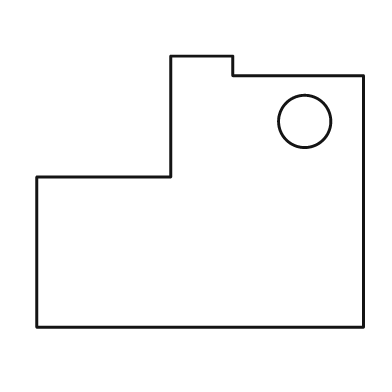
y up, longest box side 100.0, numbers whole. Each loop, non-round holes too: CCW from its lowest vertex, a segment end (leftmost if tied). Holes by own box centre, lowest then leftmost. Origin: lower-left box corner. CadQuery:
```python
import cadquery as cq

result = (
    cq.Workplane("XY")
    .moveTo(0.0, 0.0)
    .lineTo(100.0, 0.0)
    .lineTo(100.0, 77.0)
    .lineTo(60.0, 77.0)
    .lineTo(60.0, 83.0)
    .lineTo(41.0, 83.0)
    .lineTo(41.0, 46.0)
    .lineTo(0.0, 46.0)
    .close()
    .moveTo(82.0, 63.0)
    .circle(8.0)
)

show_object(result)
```